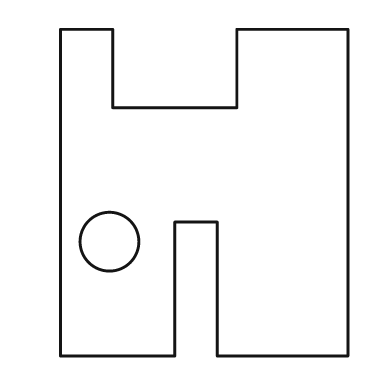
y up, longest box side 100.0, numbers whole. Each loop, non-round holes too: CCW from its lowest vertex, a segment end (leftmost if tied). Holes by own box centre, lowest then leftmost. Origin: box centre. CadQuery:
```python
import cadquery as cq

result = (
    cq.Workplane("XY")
    .moveTo(-44.0, -50.0)
    .lineTo(-9.0, -50.0)
    .lineTo(-9.0, -9.0)
    .lineTo(4.0, -9.0)
    .lineTo(4.0, -50.0)
    .lineTo(44.0, -50.0)
    .lineTo(44.0, 50.0)
    .lineTo(10.0, 50.0)
    .lineTo(10.0, 26.0)
    .lineTo(-28.0, 26.0)
    .lineTo(-28.0, 50.0)
    .lineTo(-44.0, 50.0)
    .close()
    .moveTo(-29.0, -15.0)
    .circle(9.0)
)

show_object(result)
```